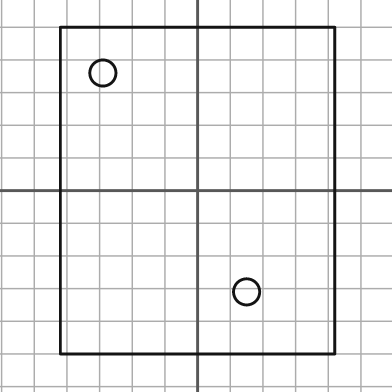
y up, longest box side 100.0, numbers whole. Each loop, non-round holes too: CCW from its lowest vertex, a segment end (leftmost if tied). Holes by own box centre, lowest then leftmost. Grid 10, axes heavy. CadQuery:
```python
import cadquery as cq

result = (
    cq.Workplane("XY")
    .moveTo(-42.0, -50.0)
    .lineTo(42.0, -50.0)
    .lineTo(42.0, 50.0)
    .lineTo(-42.0, 50.0)
    .close()
    .moveTo(15.0, -31.0)
    .circle(4.0)
    .moveTo(-29.0, 36.0)
    .circle(4.0)
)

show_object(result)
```